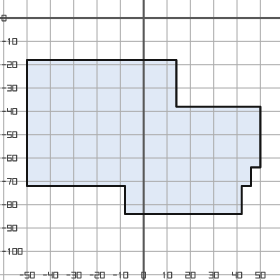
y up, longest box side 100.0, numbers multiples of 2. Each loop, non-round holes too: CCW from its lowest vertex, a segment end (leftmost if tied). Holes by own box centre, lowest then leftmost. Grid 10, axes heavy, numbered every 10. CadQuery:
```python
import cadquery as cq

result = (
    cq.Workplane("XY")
    .moveTo(-8.0, -84.0)
    .lineTo(42.0, -84.0)
    .lineTo(42.0, -72.0)
    .lineTo(46.0, -72.0)
    .lineTo(46.0, -64.0)
    .lineTo(50.0, -64.0)
    .lineTo(50.0, -38.0)
    .lineTo(14.0, -38.0)
    .lineTo(14.0, -18.0)
    .lineTo(-50.0, -18.0)
    .lineTo(-50.0, -72.0)
    .lineTo(-8.0, -72.0)
    .close()
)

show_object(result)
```